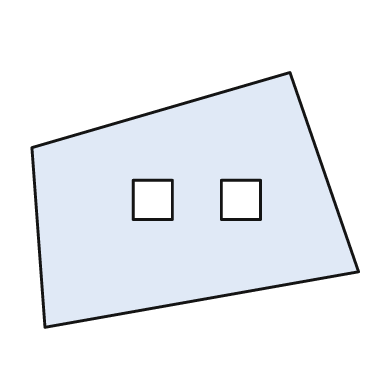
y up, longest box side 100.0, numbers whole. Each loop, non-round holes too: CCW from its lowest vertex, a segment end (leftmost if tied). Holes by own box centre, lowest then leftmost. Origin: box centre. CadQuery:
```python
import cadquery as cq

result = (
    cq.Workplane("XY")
    .moveTo(-46.0, -39.0)
    .lineTo(50.0, -22.0)
    .lineTo(29.0, 39.0)
    .lineTo(-50.0, 16.0)
    .close()
    .moveTo(-19.0, -6.0)
    .lineTo(-7.0, -6.0)
    .lineTo(-7.0, 6.0)
    .lineTo(-19.0, 6.0)
    .close()
    .moveTo(8.0, -6.0)
    .lineTo(20.0, -6.0)
    .lineTo(20.0, 6.0)
    .lineTo(8.0, 6.0)
    .close()
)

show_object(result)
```